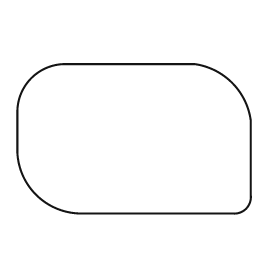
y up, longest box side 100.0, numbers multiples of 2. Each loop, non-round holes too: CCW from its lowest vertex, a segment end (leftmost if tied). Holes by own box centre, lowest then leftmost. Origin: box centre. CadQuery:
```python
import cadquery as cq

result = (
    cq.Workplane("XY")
    .moveTo(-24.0, -32.0)
    .lineTo(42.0, -32.0)
    .threePointArc((48.0, -30.0), (50.0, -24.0))
    .lineTo(50.0, 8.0)
    .threePointArc((42.0, 24.0), (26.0, 32.0))
    .lineTo(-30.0, 32.0)
    .threePointArc((-44.0, 26.0), (-50.0, 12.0))
    .lineTo(-50.0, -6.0)
    .threePointArc((-42.0, -24.0), (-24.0, -32.0))
    .close()
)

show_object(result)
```